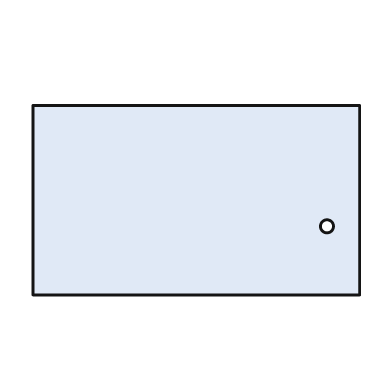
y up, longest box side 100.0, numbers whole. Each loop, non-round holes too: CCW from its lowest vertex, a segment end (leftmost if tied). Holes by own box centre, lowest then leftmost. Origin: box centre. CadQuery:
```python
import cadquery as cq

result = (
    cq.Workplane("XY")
    .moveTo(-50.0, -29.0)
    .lineTo(50.0, -29.0)
    .lineTo(50.0, 29.0)
    .lineTo(-50.0, 29.0)
    .close()
    .moveTo(40.0, -8.0)
    .circle(2.0)
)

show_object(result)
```